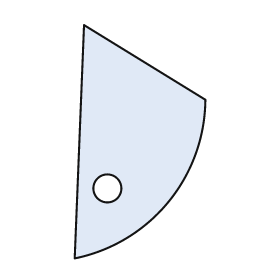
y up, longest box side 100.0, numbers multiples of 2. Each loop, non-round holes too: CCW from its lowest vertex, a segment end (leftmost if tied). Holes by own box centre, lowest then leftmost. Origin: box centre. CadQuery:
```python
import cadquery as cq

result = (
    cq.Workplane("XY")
    .moveTo(-28.0, -50.0)
    .threePointArc((12.0, -26.0), (28.0, 18.0))
    .lineTo(-24.0, 50.0)
    .close()
    .moveTo(-14.0, -20.0)
    .circle(6.0)
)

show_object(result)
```